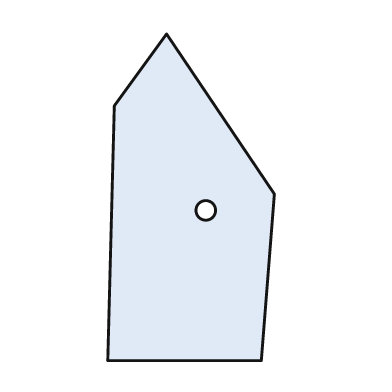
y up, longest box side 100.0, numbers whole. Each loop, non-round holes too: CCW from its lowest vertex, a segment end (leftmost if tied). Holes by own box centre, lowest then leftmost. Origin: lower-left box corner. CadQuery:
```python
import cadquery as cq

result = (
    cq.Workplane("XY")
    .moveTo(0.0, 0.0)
    .lineTo(47.0, 0.0)
    .lineTo(51.0, 51.0)
    .lineTo(18.0, 100.0)
    .lineTo(2.0, 78.0)
    .close()
    .moveTo(30.0, 46.0)
    .circle(3.0)
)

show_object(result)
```